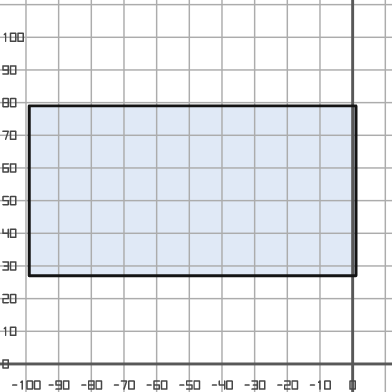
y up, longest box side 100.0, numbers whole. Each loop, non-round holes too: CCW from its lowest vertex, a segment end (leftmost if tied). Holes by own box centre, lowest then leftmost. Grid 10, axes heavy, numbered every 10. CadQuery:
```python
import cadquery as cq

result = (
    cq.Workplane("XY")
    .moveTo(-99.0, 27.0)
    .lineTo(1.0, 27.0)
    .lineTo(1.0, 79.0)
    .lineTo(-99.0, 79.0)
    .close()
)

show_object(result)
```